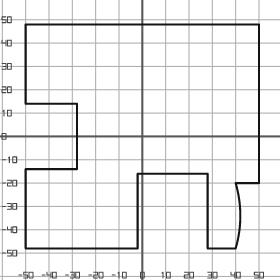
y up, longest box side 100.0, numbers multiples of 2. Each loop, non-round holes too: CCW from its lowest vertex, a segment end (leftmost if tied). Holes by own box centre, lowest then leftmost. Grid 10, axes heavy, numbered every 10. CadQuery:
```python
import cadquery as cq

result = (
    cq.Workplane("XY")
    .moveTo(-50.0, -48.0)
    .lineTo(-2.0, -48.0)
    .lineTo(-2.0, -16.0)
    .lineTo(28.0, -16.0)
    .lineTo(28.0, -48.0)
    .lineTo(40.0, -48.0)
    .threePointArc((42.0, -34.0), (40.0, -20.0))
    .lineTo(50.0, -20.0)
    .lineTo(50.0, 48.0)
    .lineTo(-50.0, 48.0)
    .lineTo(-50.0, 14.0)
    .lineTo(-28.0, 14.0)
    .lineTo(-28.0, -14.0)
    .lineTo(-50.0, -14.0)
    .close()
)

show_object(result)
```